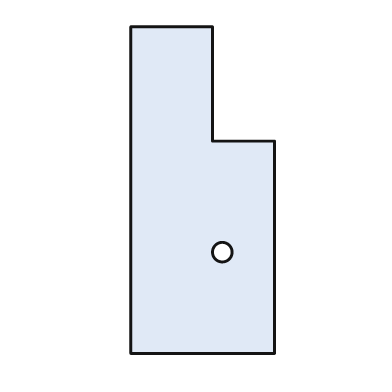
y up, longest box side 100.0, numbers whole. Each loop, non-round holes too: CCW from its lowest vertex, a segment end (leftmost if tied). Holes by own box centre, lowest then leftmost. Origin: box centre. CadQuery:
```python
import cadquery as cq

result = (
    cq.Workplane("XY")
    .moveTo(-22.0, -50.0)
    .lineTo(22.0, -50.0)
    .lineTo(22.0, 15.0)
    .lineTo(3.0, 15.0)
    .lineTo(3.0, 50.0)
    .lineTo(-22.0, 50.0)
    .close()
    .moveTo(6.0, -19.0)
    .circle(3.0)
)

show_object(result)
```